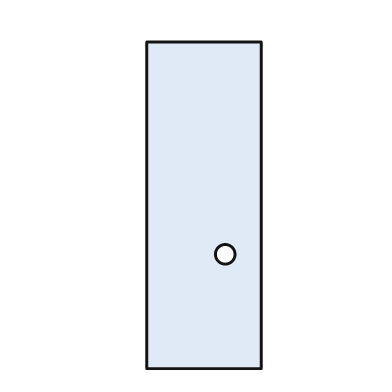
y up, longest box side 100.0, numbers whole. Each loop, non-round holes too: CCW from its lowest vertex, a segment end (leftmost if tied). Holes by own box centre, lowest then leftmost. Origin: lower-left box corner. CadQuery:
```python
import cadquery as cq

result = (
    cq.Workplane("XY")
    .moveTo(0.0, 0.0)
    .lineTo(35.0, 0.0)
    .lineTo(35.0, 100.0)
    .lineTo(0.0, 100.0)
    .close()
    .moveTo(24.0, 35.0)
    .circle(3.0)
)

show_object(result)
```